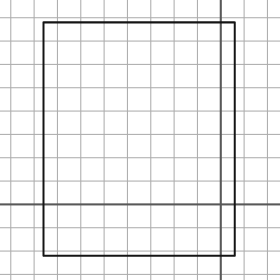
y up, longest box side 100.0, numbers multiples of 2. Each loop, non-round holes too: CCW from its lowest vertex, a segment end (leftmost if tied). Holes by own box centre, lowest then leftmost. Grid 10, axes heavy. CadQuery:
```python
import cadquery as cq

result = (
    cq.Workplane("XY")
    .moveTo(-76.0, -22.0)
    .lineTo(6.0, -22.0)
    .lineTo(6.0, 78.0)
    .lineTo(-76.0, 78.0)
    .close()
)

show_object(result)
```